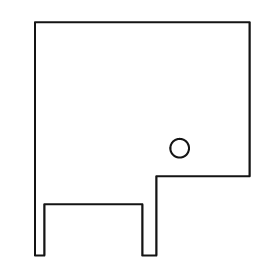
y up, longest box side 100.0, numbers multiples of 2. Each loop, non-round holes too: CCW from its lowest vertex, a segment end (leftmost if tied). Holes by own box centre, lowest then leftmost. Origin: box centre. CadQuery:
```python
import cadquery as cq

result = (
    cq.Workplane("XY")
    .moveTo(-46.0, -50.0)
    .lineTo(-42.0, -50.0)
    .lineTo(-42.0, -28.0)
    .lineTo(0.0, -28.0)
    .lineTo(0.0, -50.0)
    .lineTo(6.0, -50.0)
    .lineTo(6.0, -16.0)
    .lineTo(46.0, -16.0)
    .lineTo(46.0, 50.0)
    .lineTo(-46.0, 50.0)
    .close()
    .moveTo(16.0, -4.0)
    .circle(4.0)
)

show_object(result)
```